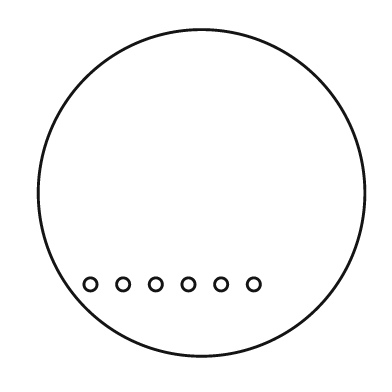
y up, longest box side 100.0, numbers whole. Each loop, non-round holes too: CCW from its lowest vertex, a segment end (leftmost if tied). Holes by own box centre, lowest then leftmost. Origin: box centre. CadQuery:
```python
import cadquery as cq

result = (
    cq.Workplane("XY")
    .moveTo(0.0, 0.0)
    .circle(50.0)
    .moveTo(-34.0, -28.0)
    .circle(2.0)
    .moveTo(-24.0, -28.0)
    .circle(2.0)
    .moveTo(-14.0, -28.0)
    .circle(2.0)
    .moveTo(-4.0, -28.0)
    .circle(2.0)
    .moveTo(6.0, -28.0)
    .circle(2.0)
    .moveTo(16.0, -28.0)
    .circle(2.0)
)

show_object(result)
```